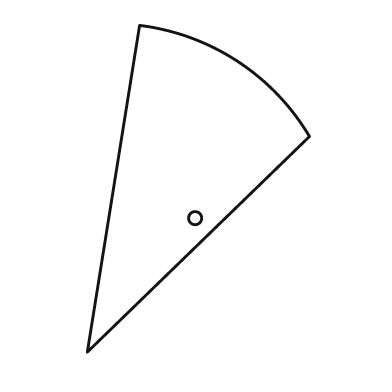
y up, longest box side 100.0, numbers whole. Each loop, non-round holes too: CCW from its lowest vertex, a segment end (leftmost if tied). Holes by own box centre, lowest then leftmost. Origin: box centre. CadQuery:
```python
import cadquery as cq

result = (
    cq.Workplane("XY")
    .moveTo(-34.0, -50.0)
    .lineTo(34.0, 16.0)
    .threePointArc((12.0, 39.0), (-18.0, 50.0))
    .close()
    .moveTo(-1.0, -9.0)
    .circle(2.0)
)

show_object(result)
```